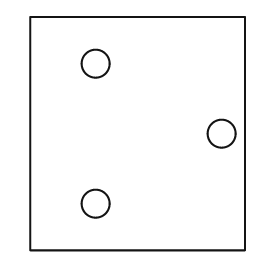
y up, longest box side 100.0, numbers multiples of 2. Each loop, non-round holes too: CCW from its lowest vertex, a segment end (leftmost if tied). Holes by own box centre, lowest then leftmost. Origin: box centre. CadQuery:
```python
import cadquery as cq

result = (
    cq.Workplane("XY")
    .moveTo(-46.0, -50.0)
    .lineTo(46.0, -50.0)
    .lineTo(46.0, 50.0)
    .lineTo(-46.0, 50.0)
    .close()
    .moveTo(-18.0, -30.0)
    .circle(6.0)
    .moveTo(36.0, 0.0)
    .circle(6.0)
    .moveTo(-18.0, 30.0)
    .circle(6.0)
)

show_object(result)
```